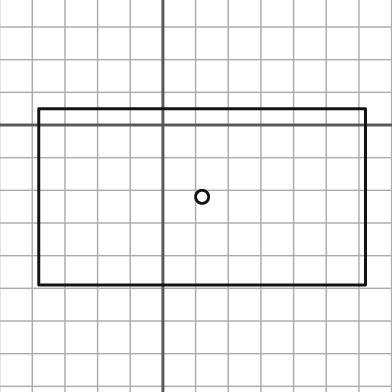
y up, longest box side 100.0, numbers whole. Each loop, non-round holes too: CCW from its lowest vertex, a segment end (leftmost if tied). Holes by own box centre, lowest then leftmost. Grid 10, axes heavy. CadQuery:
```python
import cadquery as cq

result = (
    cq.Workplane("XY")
    .moveTo(-38.0, -49.0)
    .lineTo(62.0, -49.0)
    .lineTo(62.0, 5.0)
    .lineTo(-38.0, 5.0)
    .close()
    .moveTo(12.0, -22.0)
    .circle(2.0)
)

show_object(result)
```